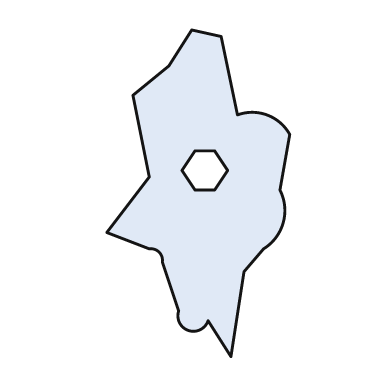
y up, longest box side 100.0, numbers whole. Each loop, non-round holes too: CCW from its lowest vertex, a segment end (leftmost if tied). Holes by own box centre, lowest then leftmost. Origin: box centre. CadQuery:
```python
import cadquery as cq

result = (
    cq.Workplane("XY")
    .moveTo(10.0, -50.0)
    .lineTo(14.0, -24.0)
    .lineTo(20.0, -17.0)
    .threePointArc((26.0, -9.0), (25.0, 1.0))
    .lineTo(28.0, 18.0)
    .threePointArc((21.0, 24.0), (12.0, 24.0))
    .lineTo(7.0, 48.0)
    .lineTo(-2.0, 50.0)
    .lineTo(-9.0, 39.0)
    .lineTo(-20.0, 30.0)
    .lineTo(-15.0, 5.0)
    .lineTo(-28.0, -12.0)
    .lineTo(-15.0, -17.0)
    .threePointArc((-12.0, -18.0), (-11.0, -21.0))
    .lineTo(-6.0, -36.0)
    .threePointArc((-3.0, -42.0), (3.0, -39.0))
    .close()
    .moveTo(-1.0, 1.0)
    .lineTo(5.0, 1.0)
    .lineTo(9.0, 7.0)
    .lineTo(5.0, 13.0)
    .lineTo(-1.0, 13.0)
    .lineTo(-5.0, 7.0)
    .close()
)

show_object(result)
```